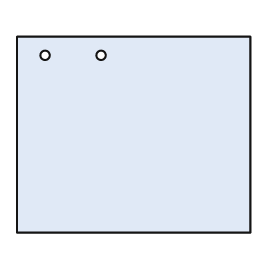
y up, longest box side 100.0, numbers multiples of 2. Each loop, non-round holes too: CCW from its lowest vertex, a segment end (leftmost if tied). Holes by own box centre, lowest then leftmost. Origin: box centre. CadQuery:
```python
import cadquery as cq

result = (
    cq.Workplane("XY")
    .moveTo(-50.0, -42.0)
    .lineTo(50.0, -42.0)
    .lineTo(50.0, 42.0)
    .lineTo(-50.0, 42.0)
    .close()
    .moveTo(-38.0, 34.0)
    .circle(2.0)
    .moveTo(-14.0, 34.0)
    .circle(2.0)
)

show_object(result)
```